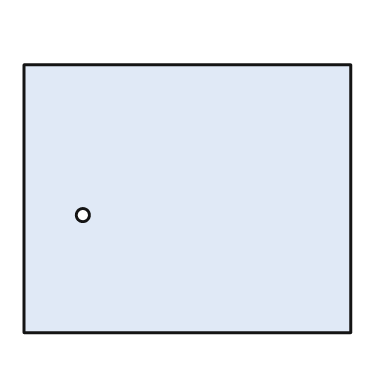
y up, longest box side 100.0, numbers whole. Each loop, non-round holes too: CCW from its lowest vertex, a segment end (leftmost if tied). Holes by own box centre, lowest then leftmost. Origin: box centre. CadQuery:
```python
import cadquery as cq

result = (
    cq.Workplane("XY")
    .moveTo(-50.0, -41.0)
    .lineTo(50.0, -41.0)
    .lineTo(50.0, 41.0)
    .lineTo(-50.0, 41.0)
    .close()
    .moveTo(-32.0, -5.0)
    .circle(2.0)
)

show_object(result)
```